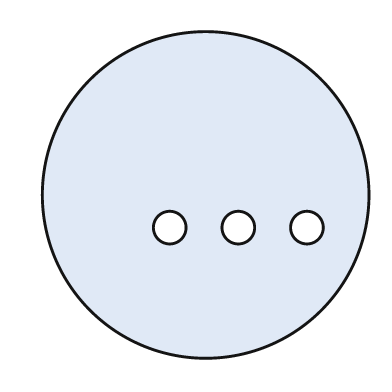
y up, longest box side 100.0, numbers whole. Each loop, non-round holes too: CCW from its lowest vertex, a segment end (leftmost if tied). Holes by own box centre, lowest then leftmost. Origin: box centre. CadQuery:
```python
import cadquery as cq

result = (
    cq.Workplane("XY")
    .moveTo(0.0, 0.0)
    .circle(50.0)
    .moveTo(-11.0, -10.0)
    .circle(5.0)
    .moveTo(10.0, -10.0)
    .circle(5.0)
    .moveTo(31.0, -10.0)
    .circle(5.0)
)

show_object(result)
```